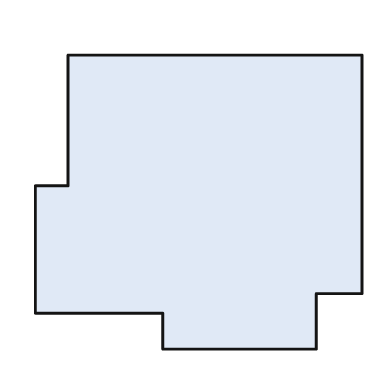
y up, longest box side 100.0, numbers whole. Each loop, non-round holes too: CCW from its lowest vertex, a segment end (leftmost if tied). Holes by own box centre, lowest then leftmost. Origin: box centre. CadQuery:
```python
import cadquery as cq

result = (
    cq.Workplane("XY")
    .moveTo(-11.0, -45.0)
    .lineTo(36.0, -45.0)
    .lineTo(36.0, -28.0)
    .lineTo(50.0, -28.0)
    .lineTo(50.0, 45.0)
    .lineTo(-40.0, 45.0)
    .lineTo(-40.0, 5.0)
    .lineTo(-50.0, 5.0)
    .lineTo(-50.0, -34.0)
    .lineTo(-11.0, -34.0)
    .close()
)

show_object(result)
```